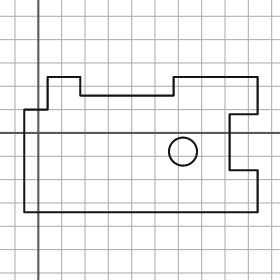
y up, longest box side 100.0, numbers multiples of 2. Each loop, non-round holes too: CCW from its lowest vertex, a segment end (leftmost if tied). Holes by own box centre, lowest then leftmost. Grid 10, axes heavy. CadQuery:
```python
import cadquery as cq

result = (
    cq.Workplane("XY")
    .moveTo(-6.0, -34.0)
    .lineTo(94.0, -34.0)
    .lineTo(94.0, -16.0)
    .lineTo(82.0, -16.0)
    .lineTo(82.0, 8.0)
    .lineTo(94.0, 8.0)
    .lineTo(94.0, 24.0)
    .lineTo(58.0, 24.0)
    .lineTo(58.0, 16.0)
    .lineTo(18.0, 16.0)
    .lineTo(18.0, 24.0)
    .lineTo(4.0, 24.0)
    .lineTo(4.0, 10.0)
    .lineTo(-6.0, 10.0)
    .close()
    .moveTo(62.0, -8.0)
    .circle(6.0)
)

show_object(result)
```